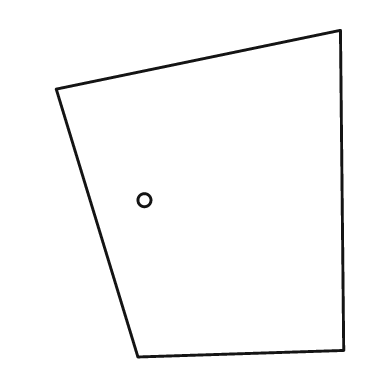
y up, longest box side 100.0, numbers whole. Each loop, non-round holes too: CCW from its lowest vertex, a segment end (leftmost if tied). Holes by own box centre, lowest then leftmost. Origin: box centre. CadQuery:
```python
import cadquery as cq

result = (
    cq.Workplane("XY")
    .moveTo(-19.0, -50.0)
    .lineTo(44.0, -48.0)
    .lineTo(43.0, 50.0)
    .lineTo(-44.0, 32.0)
    .close()
    .moveTo(-17.0, -2.0)
    .circle(2.0)
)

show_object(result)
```